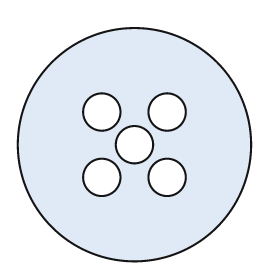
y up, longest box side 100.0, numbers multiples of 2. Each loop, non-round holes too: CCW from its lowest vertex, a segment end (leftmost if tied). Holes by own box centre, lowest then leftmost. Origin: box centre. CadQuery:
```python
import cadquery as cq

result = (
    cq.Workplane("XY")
    .moveTo(0.0, 0.0)
    .circle(50.0)
    .moveTo(-14.0, -14.0)
    .circle(8.0)
    .moveTo(14.0, -14.0)
    .circle(8.0)
    .moveTo(0.0, 0.0)
    .circle(8.0)
    .moveTo(-14.0, 14.0)
    .circle(8.0)
    .moveTo(14.0, 14.0)
    .circle(8.0)
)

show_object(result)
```